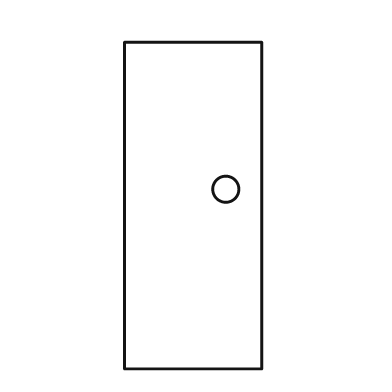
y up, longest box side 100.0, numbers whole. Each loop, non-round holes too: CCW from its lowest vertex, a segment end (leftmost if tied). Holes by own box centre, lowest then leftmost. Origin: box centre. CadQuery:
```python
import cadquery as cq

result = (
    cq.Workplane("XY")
    .moveTo(-21.0, -50.0)
    .lineTo(21.0, -50.0)
    .lineTo(21.0, 50.0)
    .lineTo(-21.0, 50.0)
    .close()
    .moveTo(10.0, 5.0)
    .circle(4.0)
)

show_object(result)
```